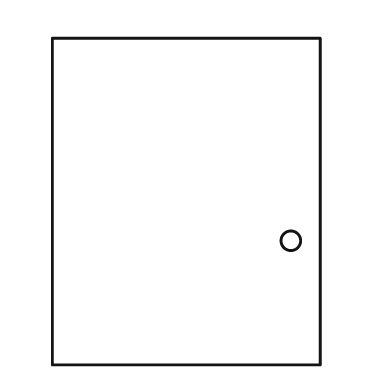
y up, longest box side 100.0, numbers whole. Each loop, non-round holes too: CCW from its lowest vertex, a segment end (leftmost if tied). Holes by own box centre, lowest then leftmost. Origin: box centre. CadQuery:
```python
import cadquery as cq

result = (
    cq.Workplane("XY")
    .moveTo(-41.0, -50.0)
    .lineTo(41.0, -50.0)
    .lineTo(41.0, 50.0)
    .lineTo(-41.0, 50.0)
    .close()
    .moveTo(32.0, -12.0)
    .circle(3.0)
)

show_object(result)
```